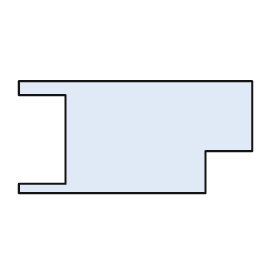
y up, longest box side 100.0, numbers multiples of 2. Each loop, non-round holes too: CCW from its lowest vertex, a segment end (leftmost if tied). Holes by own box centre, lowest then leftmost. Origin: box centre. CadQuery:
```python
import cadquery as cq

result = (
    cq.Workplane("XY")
    .moveTo(-50.0, -24.0)
    .lineTo(30.0, -24.0)
    .lineTo(30.0, -6.0)
    .lineTo(50.0, -6.0)
    .lineTo(50.0, 24.0)
    .lineTo(-50.0, 24.0)
    .lineTo(-50.0, 18.0)
    .lineTo(-30.0, 18.0)
    .lineTo(-30.0, -20.0)
    .lineTo(-50.0, -20.0)
    .close()
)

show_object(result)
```